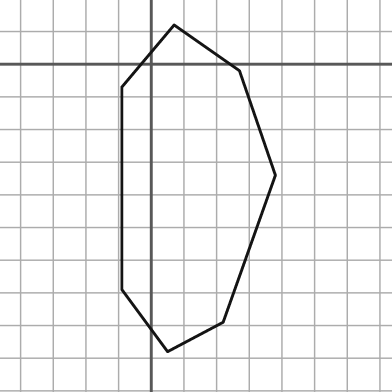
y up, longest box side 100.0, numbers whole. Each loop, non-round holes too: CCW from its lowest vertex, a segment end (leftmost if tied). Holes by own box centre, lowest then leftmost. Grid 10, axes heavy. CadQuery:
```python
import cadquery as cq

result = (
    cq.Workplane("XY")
    .moveTo(5.0, -88.0)
    .lineTo(22.0, -79.0)
    .lineTo(38.0, -34.0)
    .lineTo(27.0, -2.0)
    .lineTo(7.0, 12.0)
    .lineTo(-9.0, -7.0)
    .lineTo(-9.0, -69.0)
    .close()
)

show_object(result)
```